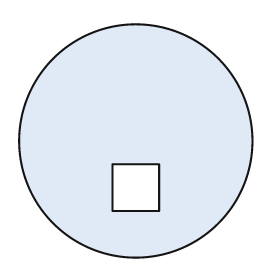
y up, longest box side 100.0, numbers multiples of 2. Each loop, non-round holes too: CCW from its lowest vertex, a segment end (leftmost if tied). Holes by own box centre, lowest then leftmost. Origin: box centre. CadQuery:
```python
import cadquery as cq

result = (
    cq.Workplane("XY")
    .moveTo(0.0, 0.0)
    .circle(50.0)
    .moveTo(-10.0, -30.0)
    .lineTo(10.0, -30.0)
    .lineTo(10.0, -10.0)
    .lineTo(-10.0, -10.0)
    .close()
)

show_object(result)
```